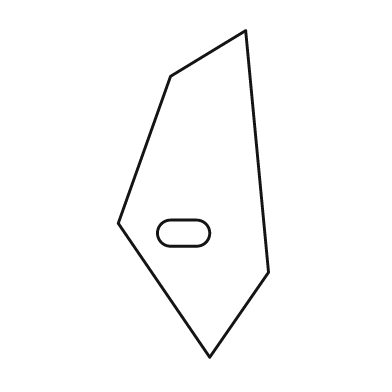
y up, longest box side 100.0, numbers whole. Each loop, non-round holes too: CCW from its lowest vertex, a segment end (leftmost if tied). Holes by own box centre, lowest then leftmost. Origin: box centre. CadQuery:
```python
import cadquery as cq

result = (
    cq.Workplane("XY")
    .moveTo(5.0, -50.0)
    .lineTo(23.0, -24.0)
    .lineTo(16.0, 50.0)
    .lineTo(-7.0, 36.0)
    .lineTo(-23.0, -9.0)
    .close()
    .moveTo(-7.0, -16.0)
    .lineTo(1.0, -16.0)
    .threePointArc((5.0, -12.0), (1.0, -8.0))
    .lineTo(-7.0, -8.0)
    .threePointArc((-11.0, -12.0), (-7.0, -16.0))
    .close()
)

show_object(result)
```